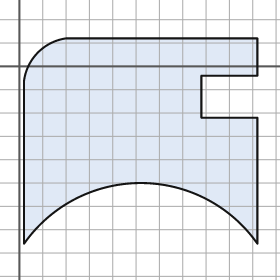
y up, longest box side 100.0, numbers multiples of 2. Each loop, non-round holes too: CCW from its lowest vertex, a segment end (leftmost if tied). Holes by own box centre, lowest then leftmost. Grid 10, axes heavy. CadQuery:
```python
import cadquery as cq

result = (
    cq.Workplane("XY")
    .moveTo(2.0, -76.0)
    .threePointArc((52.0, -50.0), (102.0, -76.0))
    .lineTo(102.0, -22.0)
    .lineTo(78.0, -22.0)
    .lineTo(78.0, -4.0)
    .lineTo(102.0, -4.0)
    .lineTo(102.0, 12.0)
    .lineTo(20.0, 12.0)
    .threePointArc((8.0, 6.0), (2.0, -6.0))
    .close()
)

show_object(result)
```